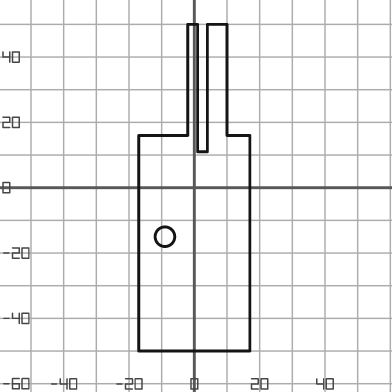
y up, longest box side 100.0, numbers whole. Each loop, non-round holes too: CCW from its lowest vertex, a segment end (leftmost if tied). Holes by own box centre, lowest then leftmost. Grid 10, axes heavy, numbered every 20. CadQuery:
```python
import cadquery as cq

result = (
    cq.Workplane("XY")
    .moveTo(-17.0, -50.0)
    .lineTo(17.0, -50.0)
    .lineTo(17.0, 16.0)
    .lineTo(10.0, 16.0)
    .lineTo(10.0, 50.0)
    .lineTo(4.0, 50.0)
    .lineTo(4.0, 11.0)
    .lineTo(1.0, 11.0)
    .lineTo(1.0, 50.0)
    .lineTo(-2.0, 50.0)
    .lineTo(-2.0, 16.0)
    .lineTo(-17.0, 16.0)
    .close()
    .moveTo(-9.0, -15.0)
    .circle(3.0)
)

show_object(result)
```